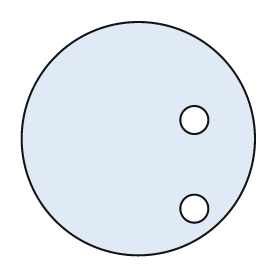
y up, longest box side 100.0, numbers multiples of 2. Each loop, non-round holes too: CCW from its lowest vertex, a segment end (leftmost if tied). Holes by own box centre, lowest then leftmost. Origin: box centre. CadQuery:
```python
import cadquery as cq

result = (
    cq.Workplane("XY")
    .moveTo(0.0, 0.0)
    .circle(50.0)
    .moveTo(24.0, -30.0)
    .circle(6.0)
    .moveTo(24.0, 8.0)
    .circle(6.0)
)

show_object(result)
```